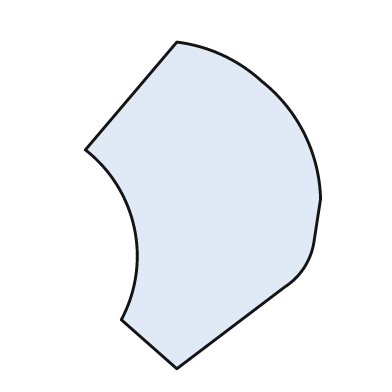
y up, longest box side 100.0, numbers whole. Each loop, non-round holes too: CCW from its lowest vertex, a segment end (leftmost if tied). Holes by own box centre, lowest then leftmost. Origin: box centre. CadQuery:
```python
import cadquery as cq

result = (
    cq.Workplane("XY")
    .moveTo(-8.0, -50.0)
    .lineTo(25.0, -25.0)
    .threePointArc((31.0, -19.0), (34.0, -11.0))
    .lineTo(36.0, 2.0)
    .threePointArc((31.0, 22.0), (18.0, 38.0))
    .threePointArc((6.0, 46.0), (-8.0, 50.0))
    .lineTo(-36.0, 17.0)
    .threePointArc((-21.0, -7.0), (-25.0, -35.0))
    .close()
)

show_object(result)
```